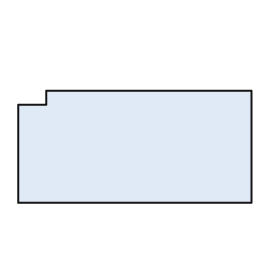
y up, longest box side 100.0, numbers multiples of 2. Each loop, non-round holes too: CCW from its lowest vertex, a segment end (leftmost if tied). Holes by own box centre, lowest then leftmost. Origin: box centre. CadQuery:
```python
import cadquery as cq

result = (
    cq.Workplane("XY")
    .moveTo(-50.0, -24.0)
    .lineTo(50.0, -24.0)
    .lineTo(50.0, 24.0)
    .lineTo(-38.0, 24.0)
    .lineTo(-38.0, 18.0)
    .lineTo(-50.0, 18.0)
    .close()
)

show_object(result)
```